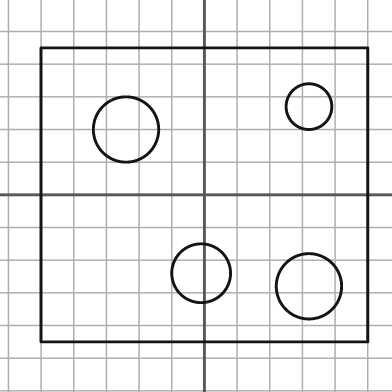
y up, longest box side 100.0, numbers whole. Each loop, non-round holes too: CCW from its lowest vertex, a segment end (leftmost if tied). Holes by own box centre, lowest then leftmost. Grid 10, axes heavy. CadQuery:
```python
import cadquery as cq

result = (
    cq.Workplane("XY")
    .moveTo(-50.0, -45.0)
    .lineTo(50.0, -45.0)
    .lineTo(50.0, 45.0)
    .lineTo(-50.0, 45.0)
    .close()
    .moveTo(32.0, -28.0)
    .circle(10.0)
    .moveTo(-1.0, -24.0)
    .circle(9.0)
    .moveTo(-24.0, 20.0)
    .circle(10.0)
    .moveTo(32.0, 27.0)
    .circle(7.0)
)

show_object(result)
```